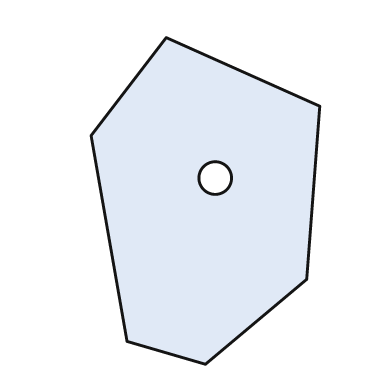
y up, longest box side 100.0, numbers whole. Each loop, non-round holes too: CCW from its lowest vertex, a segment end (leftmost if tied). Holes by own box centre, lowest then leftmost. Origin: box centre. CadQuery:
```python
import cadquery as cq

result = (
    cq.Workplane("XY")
    .moveTo(0.0, -50.0)
    .lineTo(31.0, -24.0)
    .lineTo(35.0, 29.0)
    .lineTo(-12.0, 50.0)
    .lineTo(-35.0, 20.0)
    .lineTo(-24.0, -43.0)
    .close()
    .moveTo(3.0, 7.0)
    .circle(5.0)
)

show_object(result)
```